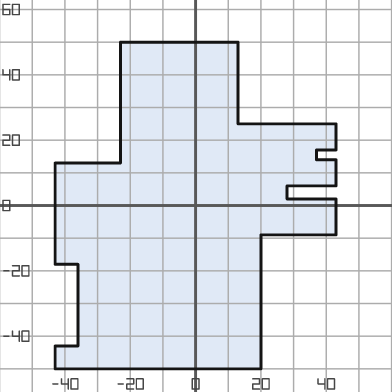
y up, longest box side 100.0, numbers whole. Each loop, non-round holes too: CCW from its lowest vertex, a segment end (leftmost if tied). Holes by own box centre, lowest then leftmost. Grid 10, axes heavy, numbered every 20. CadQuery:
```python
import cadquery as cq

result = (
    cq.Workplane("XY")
    .moveTo(-43.0, -50.0)
    .lineTo(20.0, -50.0)
    .lineTo(20.0, -9.0)
    .lineTo(43.0, -9.0)
    .lineTo(43.0, 2.0)
    .lineTo(28.0, 2.0)
    .lineTo(28.0, 6.0)
    .lineTo(43.0, 6.0)
    .lineTo(43.0, 14.0)
    .lineTo(37.0, 14.0)
    .lineTo(37.0, 17.0)
    .lineTo(43.0, 17.0)
    .lineTo(43.0, 25.0)
    .lineTo(13.0, 25.0)
    .lineTo(13.0, 50.0)
    .lineTo(-23.0, 50.0)
    .lineTo(-23.0, 13.0)
    .lineTo(-43.0, 13.0)
    .lineTo(-43.0, -18.0)
    .lineTo(-36.0, -18.0)
    .lineTo(-36.0, -43.0)
    .lineTo(-43.0, -43.0)
    .close()
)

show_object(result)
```